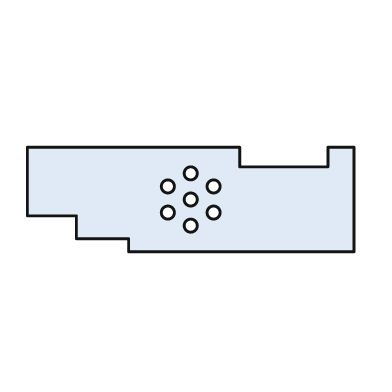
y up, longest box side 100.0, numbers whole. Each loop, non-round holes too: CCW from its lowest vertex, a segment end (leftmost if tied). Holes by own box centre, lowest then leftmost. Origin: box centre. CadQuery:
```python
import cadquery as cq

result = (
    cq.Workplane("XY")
    .moveTo(-19.0, -16.0)
    .lineTo(50.0, -16.0)
    .lineTo(50.0, 16.0)
    .lineTo(42.0, 16.0)
    .lineTo(42.0, 10.0)
    .lineTo(15.0, 10.0)
    .lineTo(15.0, 16.0)
    .lineTo(-50.0, 16.0)
    .lineTo(-50.0, -5.0)
    .lineTo(-35.0, -5.0)
    .lineTo(-35.0, -12.0)
    .lineTo(-19.0, -12.0)
    .close()
    .moveTo(0.0, -8.0)
    .circle(2.0)
    .moveTo(-7.0, -4.0)
    .circle(2.0)
    .moveTo(7.0, -4.0)
    .circle(2.0)
    .moveTo(0.0, 0.0)
    .circle(2.0)
    .moveTo(-7.0, 4.0)
    .circle(2.0)
    .moveTo(7.0, 4.0)
    .circle(2.0)
    .moveTo(0.0, 8.0)
    .circle(2.0)
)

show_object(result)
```